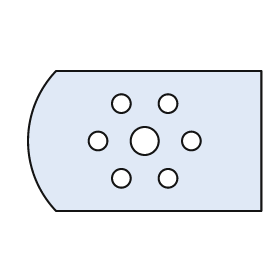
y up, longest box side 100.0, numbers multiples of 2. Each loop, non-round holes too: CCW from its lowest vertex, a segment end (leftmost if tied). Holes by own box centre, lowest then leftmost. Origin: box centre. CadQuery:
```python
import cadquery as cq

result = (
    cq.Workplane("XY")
    .moveTo(-38.0, -30.0)
    .lineTo(50.0, -30.0)
    .lineTo(50.0, 30.0)
    .lineTo(-38.0, 30.0)
    .threePointArc((-50.0, 0.0), (-38.0, -30.0))
    .close()
    .moveTo(-10.0, -16.0)
    .circle(4.0)
    .moveTo(10.0, -16.0)
    .circle(4.0)
    .moveTo(-20.0, 0.0)
    .circle(4.0)
    .moveTo(0.0, 0.0)
    .circle(6.0)
    .moveTo(20.0, 0.0)
    .circle(4.0)
    .moveTo(-10.0, 16.0)
    .circle(4.0)
    .moveTo(10.0, 16.0)
    .circle(4.0)
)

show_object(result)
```